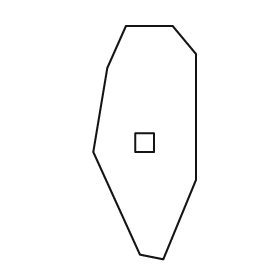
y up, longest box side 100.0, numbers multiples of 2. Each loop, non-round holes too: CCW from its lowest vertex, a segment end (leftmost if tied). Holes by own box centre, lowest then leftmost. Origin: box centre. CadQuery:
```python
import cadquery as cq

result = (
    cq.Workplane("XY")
    .moveTo(8.0, -50.0)
    .lineTo(22.0, -16.0)
    .lineTo(22.0, 38.0)
    .lineTo(12.0, 50.0)
    .lineTo(-8.0, 50.0)
    .lineTo(-16.0, 32.0)
    .lineTo(-22.0, -4.0)
    .lineTo(-2.0, -48.0)
    .close()
    .moveTo(-4.0, -4.0)
    .lineTo(4.0, -4.0)
    .lineTo(4.0, 4.0)
    .lineTo(-4.0, 4.0)
    .close()
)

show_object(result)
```